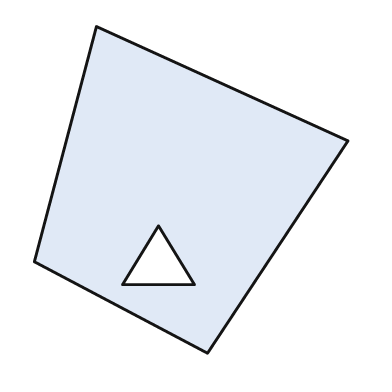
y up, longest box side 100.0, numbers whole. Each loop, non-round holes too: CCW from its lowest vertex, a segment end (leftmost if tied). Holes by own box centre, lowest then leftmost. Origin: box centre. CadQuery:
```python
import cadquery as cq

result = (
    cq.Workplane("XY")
    .moveTo(5.0, -50.0)
    .lineTo(48.0, 15.0)
    .lineTo(-29.0, 50.0)
    .lineTo(-48.0, -22.0)
    .close()
    .moveTo(-21.0, -29.0)
    .lineTo(1.0, -29.0)
    .lineTo(-10.0, -11.0)
    .close()
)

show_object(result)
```